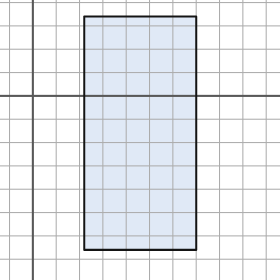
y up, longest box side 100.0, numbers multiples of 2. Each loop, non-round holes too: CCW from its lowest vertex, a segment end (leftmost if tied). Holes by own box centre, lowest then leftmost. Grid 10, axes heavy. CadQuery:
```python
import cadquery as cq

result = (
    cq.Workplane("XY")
    .moveTo(22.0, -66.0)
    .lineTo(70.0, -66.0)
    .lineTo(70.0, 34.0)
    .lineTo(22.0, 34.0)
    .close()
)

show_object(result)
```